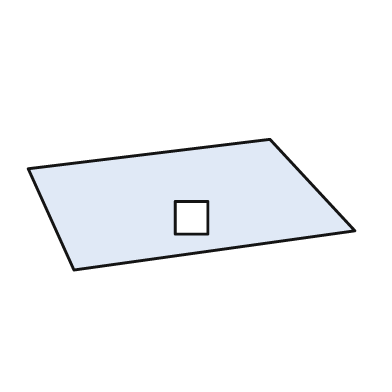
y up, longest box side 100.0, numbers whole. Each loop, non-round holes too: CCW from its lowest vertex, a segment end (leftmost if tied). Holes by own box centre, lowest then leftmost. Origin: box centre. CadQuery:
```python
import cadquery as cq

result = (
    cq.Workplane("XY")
    .moveTo(-36.0, -20.0)
    .lineTo(50.0, -8.0)
    .lineTo(24.0, 20.0)
    .lineTo(-50.0, 11.0)
    .close()
    .moveTo(-5.0, -9.0)
    .lineTo(5.0, -9.0)
    .lineTo(5.0, 1.0)
    .lineTo(-5.0, 1.0)
    .close()
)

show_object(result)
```